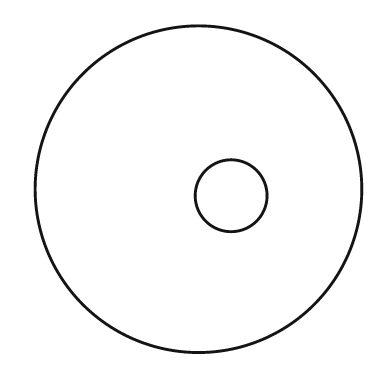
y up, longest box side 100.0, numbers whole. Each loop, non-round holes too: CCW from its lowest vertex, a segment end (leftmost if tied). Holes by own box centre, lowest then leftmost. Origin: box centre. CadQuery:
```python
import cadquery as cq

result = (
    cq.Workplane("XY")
    .moveTo(0.0, 0.0)
    .circle(50.0)
    .moveTo(10.0, -2.0)
    .circle(11.0)
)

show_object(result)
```